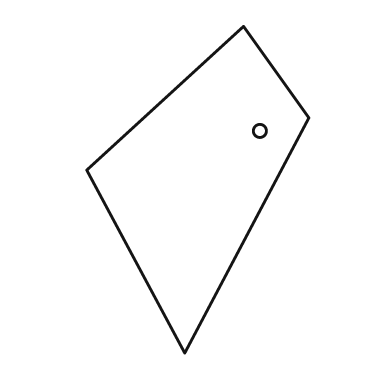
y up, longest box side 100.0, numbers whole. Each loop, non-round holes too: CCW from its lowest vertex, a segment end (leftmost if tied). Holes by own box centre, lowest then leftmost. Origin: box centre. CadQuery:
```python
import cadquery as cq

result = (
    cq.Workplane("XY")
    .moveTo(-4.0, -50.0)
    .lineTo(34.0, 22.0)
    .lineTo(14.0, 50.0)
    .lineTo(-34.0, 6.0)
    .close()
    .moveTo(19.0, 18.0)
    .circle(2.0)
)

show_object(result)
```